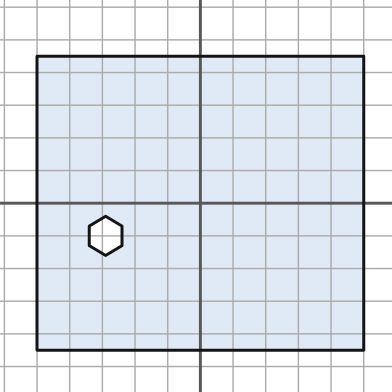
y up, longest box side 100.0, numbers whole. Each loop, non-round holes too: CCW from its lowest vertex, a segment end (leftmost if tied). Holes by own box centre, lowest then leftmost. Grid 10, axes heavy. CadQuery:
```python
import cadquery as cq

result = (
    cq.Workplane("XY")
    .moveTo(-50.0, -45.0)
    .lineTo(50.0, -45.0)
    .lineTo(50.0, 45.0)
    .lineTo(-50.0, 45.0)
    .close()
    .moveTo(-29.0, -16.0)
    .lineTo(-24.0, -13.0)
    .lineTo(-24.0, -7.0)
    .lineTo(-29.0, -4.0)
    .lineTo(-34.0, -7.0)
    .lineTo(-34.0, -13.0)
    .close()
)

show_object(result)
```